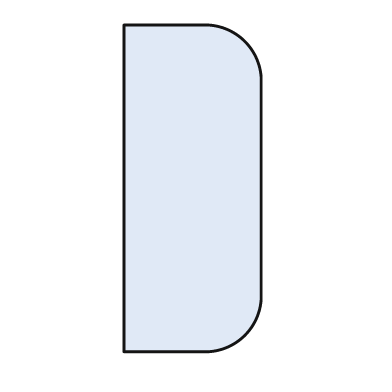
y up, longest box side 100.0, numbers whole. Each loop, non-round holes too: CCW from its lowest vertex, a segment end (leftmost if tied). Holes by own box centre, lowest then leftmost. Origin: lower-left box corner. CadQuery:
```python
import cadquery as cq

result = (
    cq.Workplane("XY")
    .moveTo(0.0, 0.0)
    .lineTo(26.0, 0.0)
    .threePointArc((37.0, 5.0), (42.0, 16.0))
    .lineTo(42.0, 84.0)
    .threePointArc((37.0, 95.0), (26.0, 100.0))
    .lineTo(0.0, 100.0)
    .close()
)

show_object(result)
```